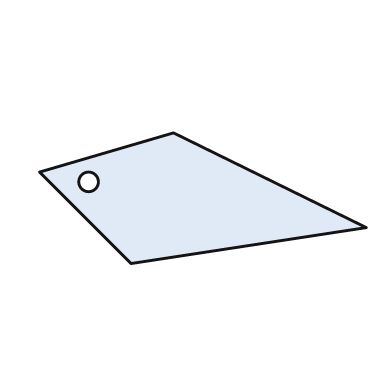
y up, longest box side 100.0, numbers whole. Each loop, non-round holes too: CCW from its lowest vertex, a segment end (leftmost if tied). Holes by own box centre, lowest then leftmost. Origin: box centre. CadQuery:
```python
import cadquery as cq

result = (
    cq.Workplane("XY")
    .moveTo(-22.0, -20.0)
    .lineTo(50.0, -9.0)
    .lineTo(-9.0, 20.0)
    .lineTo(-50.0, 8.0)
    .close()
    .moveTo(-35.0, 5.0)
    .circle(3.0)
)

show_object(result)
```